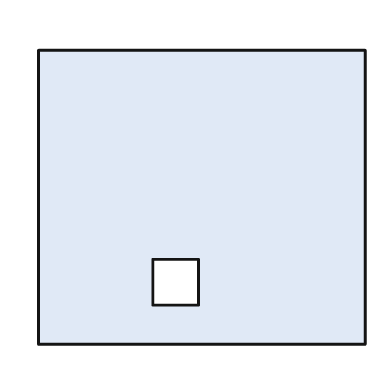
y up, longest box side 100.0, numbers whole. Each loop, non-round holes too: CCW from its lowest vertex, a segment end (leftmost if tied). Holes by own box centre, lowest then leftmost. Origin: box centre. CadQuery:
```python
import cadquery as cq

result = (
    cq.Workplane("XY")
    .moveTo(-50.0, -45.0)
    .lineTo(50.0, -45.0)
    .lineTo(50.0, 45.0)
    .lineTo(-50.0, 45.0)
    .close()
    .moveTo(-15.0, -33.0)
    .lineTo(-1.0, -33.0)
    .lineTo(-1.0, -19.0)
    .lineTo(-15.0, -19.0)
    .close()
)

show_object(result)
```